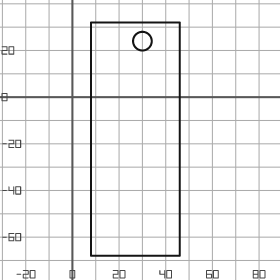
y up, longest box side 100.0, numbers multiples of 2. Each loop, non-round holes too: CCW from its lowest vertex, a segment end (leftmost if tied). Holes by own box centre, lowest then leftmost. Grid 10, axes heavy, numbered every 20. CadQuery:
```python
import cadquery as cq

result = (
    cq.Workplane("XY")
    .moveTo(8.0, -68.0)
    .lineTo(46.0, -68.0)
    .lineTo(46.0, 32.0)
    .lineTo(8.0, 32.0)
    .close()
    .moveTo(30.0, 24.0)
    .circle(4.0)
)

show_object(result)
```